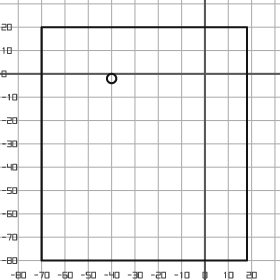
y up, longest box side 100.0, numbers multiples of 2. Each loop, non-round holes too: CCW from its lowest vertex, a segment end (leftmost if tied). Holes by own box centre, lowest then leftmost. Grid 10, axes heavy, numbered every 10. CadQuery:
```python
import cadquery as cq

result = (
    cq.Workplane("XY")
    .moveTo(-70.0, -80.0)
    .lineTo(18.0, -80.0)
    .lineTo(18.0, 20.0)
    .lineTo(-70.0, 20.0)
    .close()
    .moveTo(-40.0, -2.0)
    .circle(2.0)
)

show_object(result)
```